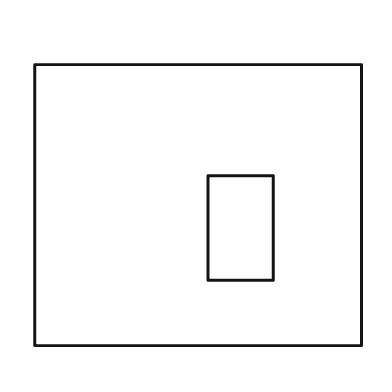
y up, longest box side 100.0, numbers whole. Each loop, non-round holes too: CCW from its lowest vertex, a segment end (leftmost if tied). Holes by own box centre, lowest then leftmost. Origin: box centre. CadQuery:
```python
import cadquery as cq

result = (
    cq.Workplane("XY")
    .moveTo(-50.0, -43.0)
    .lineTo(50.0, -43.0)
    .lineTo(50.0, 43.0)
    .lineTo(-50.0, 43.0)
    .close()
    .moveTo(3.0, -23.0)
    .lineTo(23.0, -23.0)
    .lineTo(23.0, 9.0)
    .lineTo(3.0, 9.0)
    .close()
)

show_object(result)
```